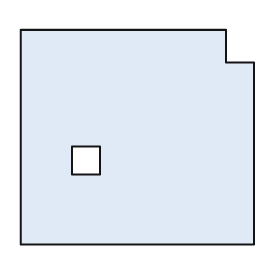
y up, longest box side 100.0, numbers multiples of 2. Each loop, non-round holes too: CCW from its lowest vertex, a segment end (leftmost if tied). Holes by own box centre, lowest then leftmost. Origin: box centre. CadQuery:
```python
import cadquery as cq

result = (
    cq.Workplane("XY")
    .moveTo(-50.0, -46.0)
    .lineTo(50.0, -46.0)
    .lineTo(50.0, 32.0)
    .lineTo(38.0, 32.0)
    .lineTo(38.0, 46.0)
    .lineTo(-50.0, 46.0)
    .close()
    .moveTo(-28.0, -16.0)
    .lineTo(-16.0, -16.0)
    .lineTo(-16.0, -4.0)
    .lineTo(-28.0, -4.0)
    .close()
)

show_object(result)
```